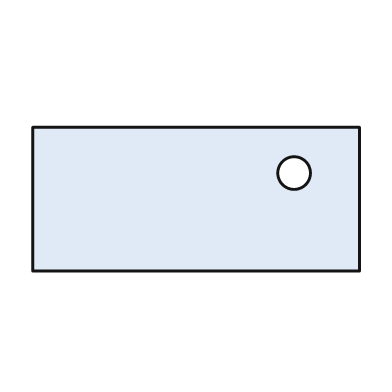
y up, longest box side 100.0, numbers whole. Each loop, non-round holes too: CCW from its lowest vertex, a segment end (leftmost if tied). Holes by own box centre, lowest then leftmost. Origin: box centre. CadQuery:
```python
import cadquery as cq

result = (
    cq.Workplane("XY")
    .moveTo(-50.0, -22.0)
    .lineTo(50.0, -22.0)
    .lineTo(50.0, 22.0)
    .lineTo(-50.0, 22.0)
    .close()
    .moveTo(30.0, 8.0)
    .circle(5.0)
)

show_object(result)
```